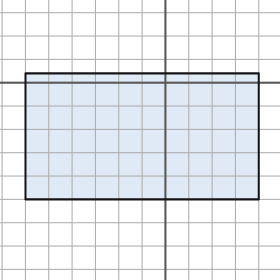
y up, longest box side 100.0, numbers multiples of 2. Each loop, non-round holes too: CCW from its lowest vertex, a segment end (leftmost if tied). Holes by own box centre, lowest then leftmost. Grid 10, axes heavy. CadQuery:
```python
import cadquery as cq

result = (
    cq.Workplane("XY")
    .moveTo(-60.0, -50.0)
    .lineTo(40.0, -50.0)
    .lineTo(40.0, 4.0)
    .lineTo(-60.0, 4.0)
    .close()
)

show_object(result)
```